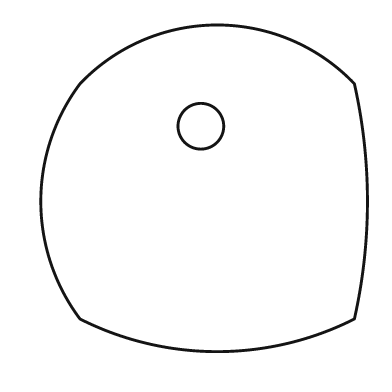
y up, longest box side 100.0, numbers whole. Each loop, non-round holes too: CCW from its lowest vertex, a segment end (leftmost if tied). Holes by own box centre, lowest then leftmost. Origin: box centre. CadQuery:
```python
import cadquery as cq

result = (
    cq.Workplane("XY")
    .moveTo(-38.0, -40.0)
    .threePointArc((4.0, -50.0), (46.0, -40.0))
    .threePointArc((50.0, -4.0), (46.0, 32.0))
    .threePointArc((4.0, 50.0), (-38.0, 32.0))
    .threePointArc((-50.0, -4.0), (-38.0, -40.0))
    .close()
    .moveTo(-1.0, 19.0)
    .circle(7.0)
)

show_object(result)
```